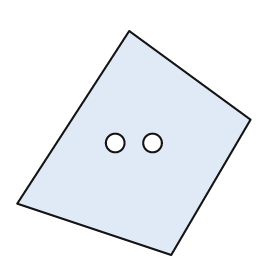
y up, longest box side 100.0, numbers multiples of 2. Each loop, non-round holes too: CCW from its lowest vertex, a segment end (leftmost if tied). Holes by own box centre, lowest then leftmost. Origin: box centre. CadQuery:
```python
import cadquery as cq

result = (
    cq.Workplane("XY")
    .moveTo(16.0, -48.0)
    .lineTo(50.0, 10.0)
    .lineTo(-2.0, 48.0)
    .lineTo(-50.0, -26.0)
    .close()
    .moveTo(-8.0, 0.0)
    .circle(4.0)
    .moveTo(8.0, 0.0)
    .circle(4.0)
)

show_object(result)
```